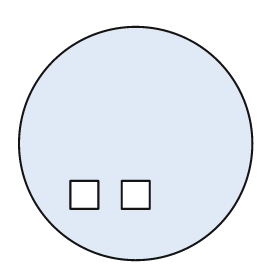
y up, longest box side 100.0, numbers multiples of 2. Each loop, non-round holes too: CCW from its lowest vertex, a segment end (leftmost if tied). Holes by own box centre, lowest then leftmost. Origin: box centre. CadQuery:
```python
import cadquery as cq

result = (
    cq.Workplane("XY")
    .moveTo(0.0, 0.0)
    .circle(50.0)
    .moveTo(-28.0, -28.0)
    .lineTo(-16.0, -28.0)
    .lineTo(-16.0, -16.0)
    .lineTo(-28.0, -16.0)
    .close()
    .moveTo(-6.0, -28.0)
    .lineTo(6.0, -28.0)
    .lineTo(6.0, -16.0)
    .lineTo(-6.0, -16.0)
    .close()
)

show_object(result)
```